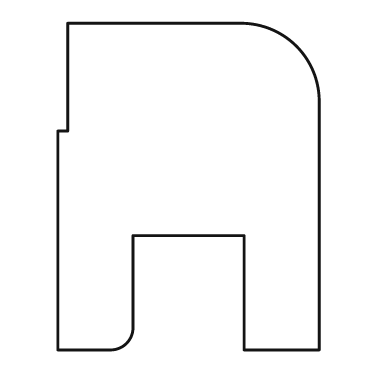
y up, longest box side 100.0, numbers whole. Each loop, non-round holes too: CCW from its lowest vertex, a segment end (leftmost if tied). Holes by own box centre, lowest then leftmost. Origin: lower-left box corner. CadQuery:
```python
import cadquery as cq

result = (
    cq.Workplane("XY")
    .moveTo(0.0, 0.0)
    .lineTo(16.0, 0.0)
    .threePointArc((21.0, 2.0), (23.0, 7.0))
    .lineTo(23.0, 35.0)
    .lineTo(57.0, 35.0)
    .lineTo(57.0, 0.0)
    .lineTo(80.0, 0.0)
    .lineTo(80.0, 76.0)
    .threePointArc((73.0, 93.0), (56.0, 100.0))
    .lineTo(3.0, 100.0)
    .lineTo(3.0, 67.0)
    .lineTo(0.0, 67.0)
    .close()
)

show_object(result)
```